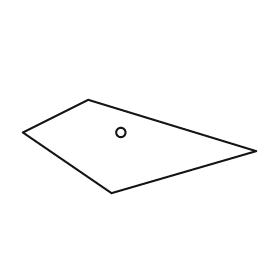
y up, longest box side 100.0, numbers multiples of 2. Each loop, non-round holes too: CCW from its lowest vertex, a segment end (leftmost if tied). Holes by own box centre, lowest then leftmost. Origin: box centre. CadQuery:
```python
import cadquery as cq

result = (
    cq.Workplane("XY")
    .moveTo(-12.0, -20.0)
    .lineTo(50.0, -2.0)
    .lineTo(-22.0, 20.0)
    .lineTo(-50.0, 6.0)
    .close()
    .moveTo(-8.0, 6.0)
    .circle(2.0)
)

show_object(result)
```